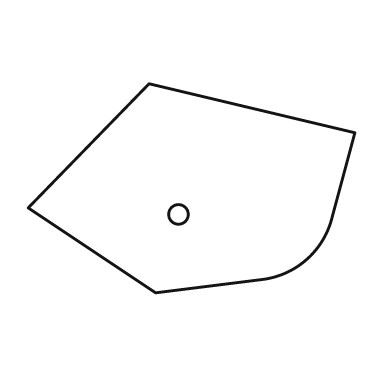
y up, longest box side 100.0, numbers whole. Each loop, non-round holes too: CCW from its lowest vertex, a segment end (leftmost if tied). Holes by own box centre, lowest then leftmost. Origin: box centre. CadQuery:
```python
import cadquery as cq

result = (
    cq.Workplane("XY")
    .moveTo(-11.0, -32.0)
    .lineTo(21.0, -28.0)
    .threePointArc((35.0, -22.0), (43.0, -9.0))
    .lineTo(50.0, 17.0)
    .lineTo(-13.0, 32.0)
    .lineTo(-50.0, -6.0)
    .close()
    .moveTo(-4.0, -8.0)
    .circle(3.0)
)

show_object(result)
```